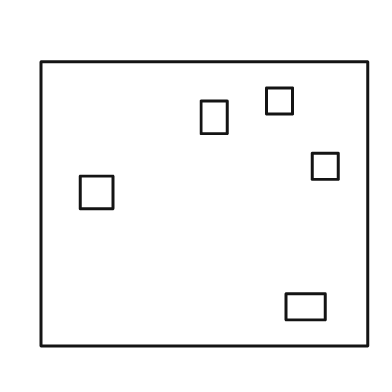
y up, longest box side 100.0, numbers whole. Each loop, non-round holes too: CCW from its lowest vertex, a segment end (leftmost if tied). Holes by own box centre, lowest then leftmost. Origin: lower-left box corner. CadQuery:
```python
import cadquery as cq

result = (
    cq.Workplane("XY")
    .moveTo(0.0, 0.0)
    .lineTo(100.0, 0.0)
    .lineTo(100.0, 87.0)
    .lineTo(0.0, 87.0)
    .close()
    .moveTo(75.0, 8.0)
    .lineTo(87.0, 8.0)
    .lineTo(87.0, 16.0)
    .lineTo(75.0, 16.0)
    .close()
    .moveTo(12.0, 42.0)
    .lineTo(22.0, 42.0)
    .lineTo(22.0, 52.0)
    .lineTo(12.0, 52.0)
    .close()
    .moveTo(83.0, 51.0)
    .lineTo(91.0, 51.0)
    .lineTo(91.0, 59.0)
    .lineTo(83.0, 59.0)
    .close()
    .moveTo(49.0, 65.0)
    .lineTo(57.0, 65.0)
    .lineTo(57.0, 75.0)
    .lineTo(49.0, 75.0)
    .close()
    .moveTo(69.0, 71.0)
    .lineTo(77.0, 71.0)
    .lineTo(77.0, 79.0)
    .lineTo(69.0, 79.0)
    .close()
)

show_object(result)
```